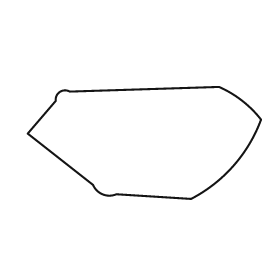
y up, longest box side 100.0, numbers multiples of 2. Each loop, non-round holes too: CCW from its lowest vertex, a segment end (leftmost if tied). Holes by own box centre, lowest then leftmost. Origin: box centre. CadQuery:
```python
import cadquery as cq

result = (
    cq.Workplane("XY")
    .moveTo(20.0, -24.0)
    .threePointArc((38.0, -10.0), (50.0, 10.0))
    .threePointArc((42.0, 18.0), (32.0, 24.0))
    .lineTo(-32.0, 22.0)
    .threePointArc((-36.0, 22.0), (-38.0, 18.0))
    .lineTo(-50.0, 4.0)
    .lineTo(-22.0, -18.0)
    .threePointArc((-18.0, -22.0), (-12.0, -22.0))
    .close()
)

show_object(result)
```